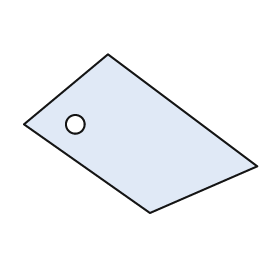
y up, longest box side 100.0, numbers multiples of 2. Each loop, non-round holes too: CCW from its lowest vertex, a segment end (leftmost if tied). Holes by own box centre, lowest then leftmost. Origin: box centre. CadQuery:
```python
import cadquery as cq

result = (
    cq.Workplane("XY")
    .moveTo(4.0, -34.0)
    .lineTo(50.0, -14.0)
    .lineTo(-14.0, 34.0)
    .lineTo(-50.0, 4.0)
    .close()
    .moveTo(-28.0, 4.0)
    .circle(4.0)
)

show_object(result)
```